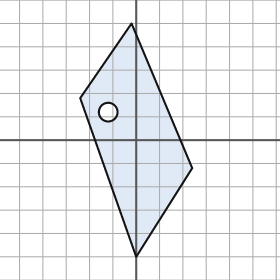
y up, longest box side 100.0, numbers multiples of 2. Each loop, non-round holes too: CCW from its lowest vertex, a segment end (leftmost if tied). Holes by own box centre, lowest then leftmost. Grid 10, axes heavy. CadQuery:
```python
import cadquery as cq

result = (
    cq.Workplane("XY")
    .moveTo(0.0, -50.0)
    .lineTo(24.0, -12.0)
    .lineTo(-2.0, 50.0)
    .lineTo(-24.0, 18.0)
    .close()
    .moveTo(-12.0, 12.0)
    .circle(4.0)
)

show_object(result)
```